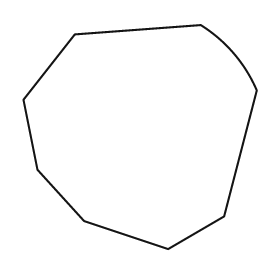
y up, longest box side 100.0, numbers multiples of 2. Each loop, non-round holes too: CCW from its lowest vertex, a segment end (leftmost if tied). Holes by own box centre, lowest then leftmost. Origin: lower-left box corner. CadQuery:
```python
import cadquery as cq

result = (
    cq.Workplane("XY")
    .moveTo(62.0, 0.0)
    .lineTo(86.0, 14.0)
    .lineTo(100.0, 68.0)
    .threePointArc((90.0, 84.0), (76.0, 96.0))
    .lineTo(22.0, 92.0)
    .lineTo(0.0, 64.0)
    .lineTo(6.0, 34.0)
    .lineTo(26.0, 12.0)
    .close()
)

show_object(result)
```